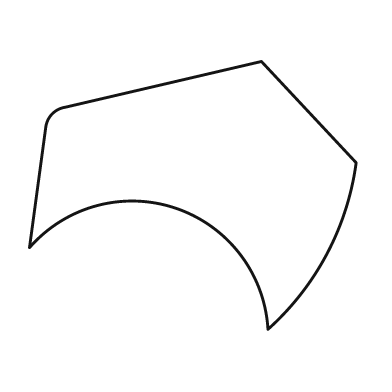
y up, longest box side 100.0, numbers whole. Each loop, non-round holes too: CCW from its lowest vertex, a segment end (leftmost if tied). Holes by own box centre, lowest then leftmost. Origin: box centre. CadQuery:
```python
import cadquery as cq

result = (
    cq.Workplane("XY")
    .moveTo(23.0, -41.0)
    .threePointArc((41.0, -18.0), (50.0, 10.0))
    .lineTo(21.0, 41.0)
    .lineTo(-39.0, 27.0)
    .threePointArc((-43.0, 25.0), (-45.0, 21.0))
    .lineTo(-50.0, -16.0)
    .threePointArc((-5.0, -4.0), (23.0, -41.0))
    .close()
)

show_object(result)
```